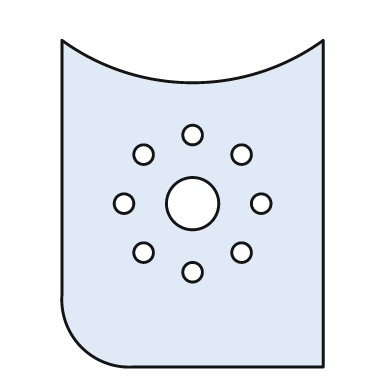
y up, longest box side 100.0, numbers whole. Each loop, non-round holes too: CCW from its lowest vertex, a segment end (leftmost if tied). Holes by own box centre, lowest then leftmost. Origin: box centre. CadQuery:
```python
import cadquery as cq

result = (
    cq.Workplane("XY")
    .moveTo(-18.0, -50.0)
    .lineTo(40.0, -50.0)
    .lineTo(40.0, 50.0)
    .threePointArc((0.0, 37.0), (-40.0, 50.0))
    .lineTo(-40.0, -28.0)
    .threePointArc((-34.0, -44.0), (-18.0, -50.0))
    .close()
    .moveTo(0.0, -21.0)
    .circle(3.0)
    .moveTo(-15.0, -15.0)
    .circle(3.0)
    .moveTo(15.0, -15.0)
    .circle(3.0)
    .moveTo(-21.0, 0.0)
    .circle(3.0)
    .moveTo(0.0, 0.0)
    .circle(8.0)
    .moveTo(21.0, 0.0)
    .circle(3.0)
    .moveTo(-15.0, 15.0)
    .circle(3.0)
    .moveTo(15.0, 15.0)
    .circle(3.0)
    .moveTo(0.0, 21.0)
    .circle(3.0)
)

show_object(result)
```